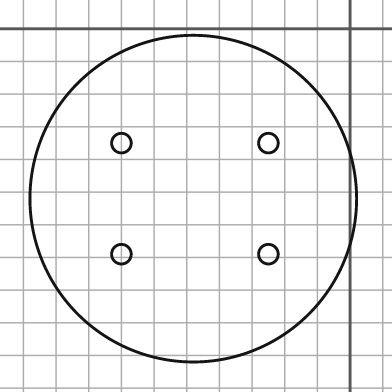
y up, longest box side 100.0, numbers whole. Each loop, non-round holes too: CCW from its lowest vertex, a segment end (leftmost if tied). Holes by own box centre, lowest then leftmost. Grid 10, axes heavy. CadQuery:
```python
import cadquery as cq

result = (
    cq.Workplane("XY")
    .moveTo(-48.0, -52.0)
    .circle(50.0)
    .moveTo(-70.0, -69.0)
    .circle(3.0)
    .moveTo(-25.0, -69.0)
    .circle(3.0)
    .moveTo(-70.0, -35.0)
    .circle(3.0)
    .moveTo(-25.0, -35.0)
    .circle(3.0)
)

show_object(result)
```